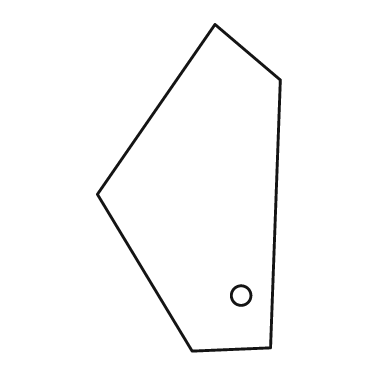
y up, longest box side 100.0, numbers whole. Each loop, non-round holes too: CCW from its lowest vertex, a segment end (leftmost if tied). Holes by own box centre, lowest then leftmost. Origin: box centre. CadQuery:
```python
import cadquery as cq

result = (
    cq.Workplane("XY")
    .moveTo(1.0, -50.0)
    .lineTo(25.0, -49.0)
    .lineTo(28.0, 33.0)
    .lineTo(8.0, 50.0)
    .lineTo(-28.0, -2.0)
    .close()
    .moveTo(16.0, -33.0)
    .circle(3.0)
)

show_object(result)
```